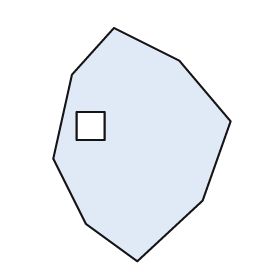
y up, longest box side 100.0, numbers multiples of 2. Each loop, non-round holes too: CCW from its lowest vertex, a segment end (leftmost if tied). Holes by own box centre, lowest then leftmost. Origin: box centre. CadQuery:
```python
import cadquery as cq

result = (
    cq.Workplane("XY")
    .moveTo(-2.0, -50.0)
    .lineTo(26.0, -24.0)
    .lineTo(38.0, 10.0)
    .lineTo(16.0, 36.0)
    .lineTo(-12.0, 50.0)
    .lineTo(-30.0, 30.0)
    .lineTo(-38.0, -6.0)
    .lineTo(-24.0, -34.0)
    .close()
    .moveTo(-28.0, 2.0)
    .lineTo(-16.0, 2.0)
    .lineTo(-16.0, 14.0)
    .lineTo(-28.0, 14.0)
    .close()
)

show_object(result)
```